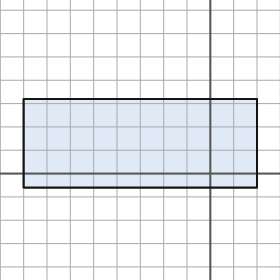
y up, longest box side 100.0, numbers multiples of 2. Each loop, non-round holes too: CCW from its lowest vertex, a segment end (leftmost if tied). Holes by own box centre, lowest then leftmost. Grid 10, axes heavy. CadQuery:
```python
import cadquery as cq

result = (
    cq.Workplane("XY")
    .moveTo(-80.0, -6.0)
    .lineTo(20.0, -6.0)
    .lineTo(20.0, 32.0)
    .lineTo(-80.0, 32.0)
    .close()
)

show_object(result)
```